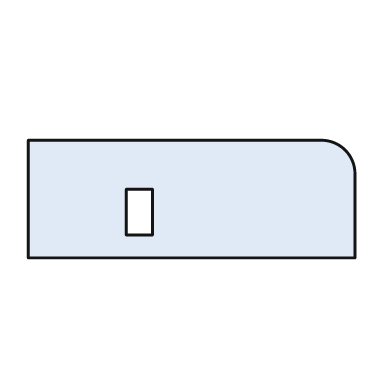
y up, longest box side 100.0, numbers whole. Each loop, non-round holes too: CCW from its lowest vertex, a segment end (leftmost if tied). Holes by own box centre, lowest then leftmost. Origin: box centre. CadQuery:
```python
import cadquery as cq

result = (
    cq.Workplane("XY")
    .moveTo(-50.0, -18.0)
    .lineTo(50.0, -18.0)
    .lineTo(50.0, 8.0)
    .threePointArc((47.0, 15.0), (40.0, 18.0))
    .lineTo(-50.0, 18.0)
    .close()
    .moveTo(-20.0, -11.0)
    .lineTo(-12.0, -11.0)
    .lineTo(-12.0, 3.0)
    .lineTo(-20.0, 3.0)
    .close()
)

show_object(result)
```